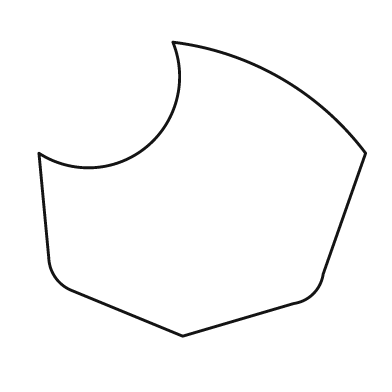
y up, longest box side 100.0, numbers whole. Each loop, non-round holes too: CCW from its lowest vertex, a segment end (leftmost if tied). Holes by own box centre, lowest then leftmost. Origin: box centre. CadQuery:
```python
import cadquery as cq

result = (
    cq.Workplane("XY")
    .moveTo(-6.0, -45.0)
    .lineTo(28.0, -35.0)
    .threePointArc((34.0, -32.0), (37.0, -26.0))
    .lineTo(50.0, 11.0)
    .threePointArc((24.0, 34.0), (-9.0, 45.0))
    .threePointArc((-17.0, 13.0), (-50.0, 11.0))
    .lineTo(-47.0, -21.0)
    .threePointArc((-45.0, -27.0), (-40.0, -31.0))
    .close()
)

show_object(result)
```